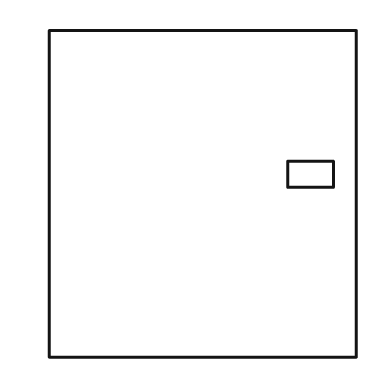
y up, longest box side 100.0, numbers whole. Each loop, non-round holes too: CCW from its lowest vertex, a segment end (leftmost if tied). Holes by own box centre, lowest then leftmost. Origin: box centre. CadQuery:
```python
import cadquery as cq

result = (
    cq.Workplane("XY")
    .moveTo(-47.0, -50.0)
    .lineTo(47.0, -50.0)
    .lineTo(47.0, 50.0)
    .lineTo(-47.0, 50.0)
    .close()
    .moveTo(26.0, 2.0)
    .lineTo(40.0, 2.0)
    .lineTo(40.0, 10.0)
    .lineTo(26.0, 10.0)
    .close()
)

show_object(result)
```